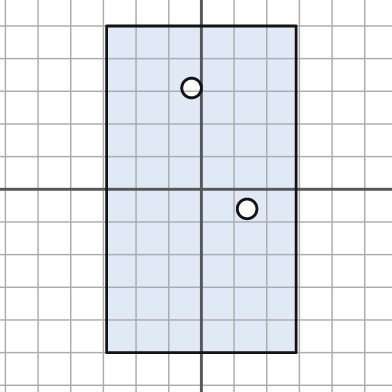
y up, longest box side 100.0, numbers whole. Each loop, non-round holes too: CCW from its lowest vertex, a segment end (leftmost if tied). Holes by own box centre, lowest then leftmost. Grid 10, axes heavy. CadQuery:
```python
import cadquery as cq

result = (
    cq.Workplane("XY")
    .moveTo(-29.0, -50.0)
    .lineTo(29.0, -50.0)
    .lineTo(29.0, 50.0)
    .lineTo(-29.0, 50.0)
    .close()
    .moveTo(14.0, -6.0)
    .circle(3.0)
    .moveTo(-3.0, 31.0)
    .circle(3.0)
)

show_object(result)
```